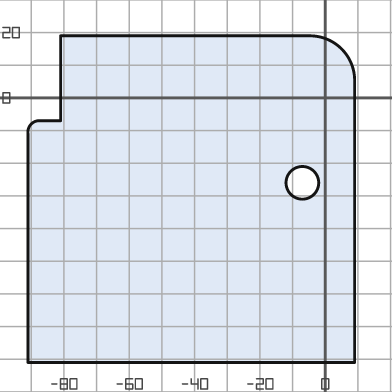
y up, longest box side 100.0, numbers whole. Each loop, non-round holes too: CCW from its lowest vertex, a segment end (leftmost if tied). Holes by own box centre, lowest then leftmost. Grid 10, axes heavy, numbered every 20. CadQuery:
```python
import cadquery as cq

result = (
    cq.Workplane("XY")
    .moveTo(-91.0, -81.0)
    .lineTo(9.0, -81.0)
    .lineTo(9.0, 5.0)
    .threePointArc((5.0, 15.0), (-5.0, 19.0))
    .lineTo(-81.0, 19.0)
    .lineTo(-81.0, -7.0)
    .lineTo(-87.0, -7.0)
    .threePointArc((-90.0, -8.0), (-91.0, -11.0))
    .close()
    .moveTo(-7.0, -26.0)
    .circle(5.0)
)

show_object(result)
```